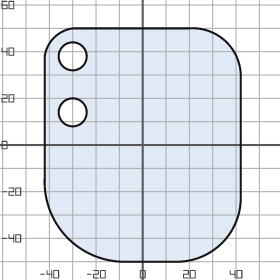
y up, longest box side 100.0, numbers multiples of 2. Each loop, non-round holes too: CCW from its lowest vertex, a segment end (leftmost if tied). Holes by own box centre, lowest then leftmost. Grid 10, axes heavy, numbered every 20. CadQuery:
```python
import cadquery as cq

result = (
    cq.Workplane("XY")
    .moveTo(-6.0, -50.0)
    .lineTo(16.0, -50.0)
    .threePointArc((34.0, -42.0), (42.0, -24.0))
    .lineTo(42.0, 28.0)
    .threePointArc((36.0, 44.0), (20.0, 50.0))
    .lineTo(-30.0, 50.0)
    .threePointArc((-38.0, 46.0), (-42.0, 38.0))
    .lineTo(-42.0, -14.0)
    .threePointArc((-32.0, -40.0), (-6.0, -50.0))
    .close()
    .moveTo(-30.0, 14.0)
    .circle(6.0)
    .moveTo(-30.0, 38.0)
    .circle(6.0)
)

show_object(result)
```